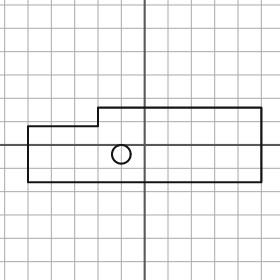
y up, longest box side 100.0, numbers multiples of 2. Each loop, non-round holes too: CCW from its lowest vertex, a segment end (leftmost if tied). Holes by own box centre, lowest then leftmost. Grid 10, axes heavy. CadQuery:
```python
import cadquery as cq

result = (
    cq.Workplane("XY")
    .moveTo(-50.0, -16.0)
    .lineTo(50.0, -16.0)
    .lineTo(50.0, 16.0)
    .lineTo(-20.0, 16.0)
    .lineTo(-20.0, 8.0)
    .lineTo(-50.0, 8.0)
    .close()
    .moveTo(-10.0, -4.0)
    .circle(4.0)
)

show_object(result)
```